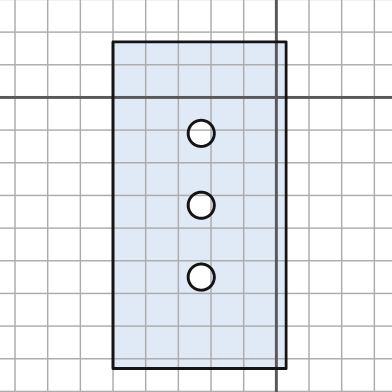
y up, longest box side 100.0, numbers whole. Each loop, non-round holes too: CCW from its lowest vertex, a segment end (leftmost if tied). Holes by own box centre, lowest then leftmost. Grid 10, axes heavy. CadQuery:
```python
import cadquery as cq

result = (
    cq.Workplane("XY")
    .moveTo(-50.0, -83.0)
    .lineTo(3.0, -83.0)
    .lineTo(3.0, 17.0)
    .lineTo(-50.0, 17.0)
    .close()
    .moveTo(-23.0, -55.0)
    .circle(4.0)
    .moveTo(-23.0, -33.0)
    .circle(4.0)
    .moveTo(-23.0, -11.0)
    .circle(4.0)
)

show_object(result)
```